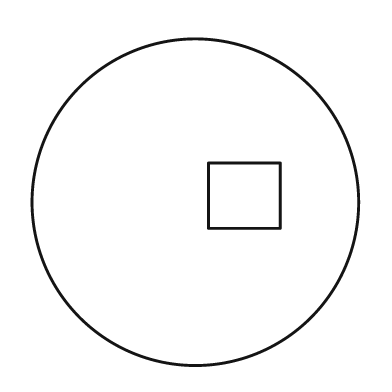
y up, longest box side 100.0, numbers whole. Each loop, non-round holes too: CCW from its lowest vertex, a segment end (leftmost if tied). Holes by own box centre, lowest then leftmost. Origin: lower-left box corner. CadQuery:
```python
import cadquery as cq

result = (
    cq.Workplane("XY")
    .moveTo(50.0, 50.0)
    .circle(50.0)
    .moveTo(54.0, 42.0)
    .lineTo(76.0, 42.0)
    .lineTo(76.0, 62.0)
    .lineTo(54.0, 62.0)
    .close()
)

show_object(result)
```